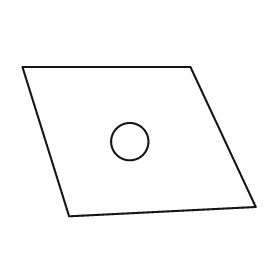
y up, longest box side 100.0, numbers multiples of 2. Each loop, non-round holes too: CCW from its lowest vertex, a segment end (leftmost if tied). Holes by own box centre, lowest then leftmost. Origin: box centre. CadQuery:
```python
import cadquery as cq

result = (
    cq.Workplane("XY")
    .moveTo(-30.0, -32.0)
    .lineTo(50.0, -28.0)
    .lineTo(22.0, 32.0)
    .lineTo(-50.0, 32.0)
    .close()
    .moveTo(-4.0, 0.0)
    .circle(8.0)
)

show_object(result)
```